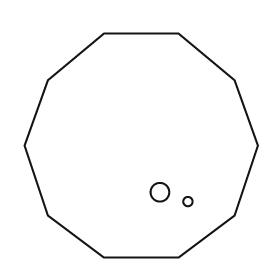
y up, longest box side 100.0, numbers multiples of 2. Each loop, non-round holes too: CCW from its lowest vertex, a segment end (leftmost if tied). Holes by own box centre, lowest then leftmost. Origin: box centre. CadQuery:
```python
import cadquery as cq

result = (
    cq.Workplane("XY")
    .moveTo(-16.0, -48.0)
    .lineTo(16.0, -48.0)
    .lineTo(40.0, -30.0)
    .lineTo(50.0, 0.0)
    .lineTo(40.0, 28.0)
    .lineTo(16.0, 48.0)
    .lineTo(-16.0, 48.0)
    .lineTo(-40.0, 28.0)
    .lineTo(-50.0, 0.0)
    .lineTo(-40.0, -30.0)
    .close()
    .moveTo(20.0, -24.0)
    .circle(2.0)
    .moveTo(8.0, -20.0)
    .circle(4.0)
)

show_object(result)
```